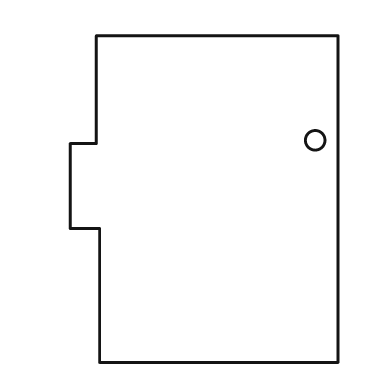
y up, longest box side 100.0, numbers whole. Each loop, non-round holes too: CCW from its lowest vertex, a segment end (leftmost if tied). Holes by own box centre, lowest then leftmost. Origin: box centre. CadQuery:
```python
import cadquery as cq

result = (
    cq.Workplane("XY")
    .moveTo(-32.0, -50.0)
    .lineTo(41.0, -50.0)
    .lineTo(41.0, 50.0)
    .lineTo(-33.0, 50.0)
    .lineTo(-33.0, 17.0)
    .lineTo(-41.0, 17.0)
    .lineTo(-41.0, -9.0)
    .lineTo(-32.0, -9.0)
    .close()
    .moveTo(34.0, 18.0)
    .circle(3.0)
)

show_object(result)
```